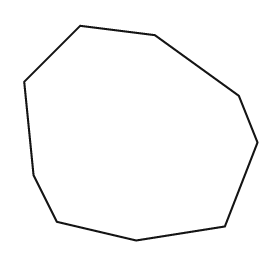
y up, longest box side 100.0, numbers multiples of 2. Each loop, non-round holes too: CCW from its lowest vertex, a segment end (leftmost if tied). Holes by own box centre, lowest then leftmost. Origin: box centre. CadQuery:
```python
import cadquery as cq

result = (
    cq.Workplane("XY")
    .moveTo(-2.0, -46.0)
    .lineTo(36.0, -40.0)
    .lineTo(50.0, -4.0)
    .lineTo(42.0, 16.0)
    .lineTo(6.0, 42.0)
    .lineTo(-26.0, 46.0)
    .lineTo(-50.0, 22.0)
    .lineTo(-46.0, -18.0)
    .lineTo(-36.0, -38.0)
    .close()
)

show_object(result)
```